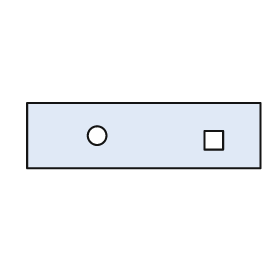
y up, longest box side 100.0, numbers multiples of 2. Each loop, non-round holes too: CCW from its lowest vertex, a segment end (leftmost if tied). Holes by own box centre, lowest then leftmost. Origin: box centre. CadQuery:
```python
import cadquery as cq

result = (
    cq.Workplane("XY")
    .moveTo(-50.0, -14.0)
    .lineTo(50.0, -14.0)
    .lineTo(50.0, 14.0)
    .lineTo(-50.0, 14.0)
    .close()
    .moveTo(26.0, -6.0)
    .lineTo(34.0, -6.0)
    .lineTo(34.0, 2.0)
    .lineTo(26.0, 2.0)
    .close()
    .moveTo(-20.0, 0.0)
    .circle(4.0)
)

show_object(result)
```